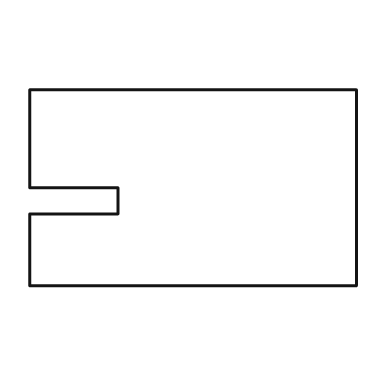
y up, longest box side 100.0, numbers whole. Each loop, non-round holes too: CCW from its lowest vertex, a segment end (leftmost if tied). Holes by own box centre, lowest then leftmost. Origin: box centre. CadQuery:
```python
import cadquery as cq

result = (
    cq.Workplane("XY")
    .moveTo(-50.0, -30.0)
    .lineTo(50.0, -30.0)
    .lineTo(50.0, 30.0)
    .lineTo(-50.0, 30.0)
    .lineTo(-50.0, 0.0)
    .lineTo(-23.0, 0.0)
    .lineTo(-23.0, -8.0)
    .lineTo(-50.0, -8.0)
    .close()
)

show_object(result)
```